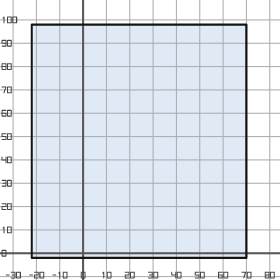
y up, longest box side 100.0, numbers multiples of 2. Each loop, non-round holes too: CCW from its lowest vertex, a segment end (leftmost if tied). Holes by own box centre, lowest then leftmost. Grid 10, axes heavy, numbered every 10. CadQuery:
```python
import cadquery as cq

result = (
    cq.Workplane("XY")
    .moveTo(-22.0, -2.0)
    .lineTo(70.0, -2.0)
    .lineTo(70.0, 98.0)
    .lineTo(-22.0, 98.0)
    .close()
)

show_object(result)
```